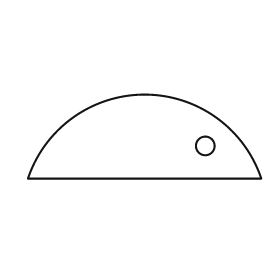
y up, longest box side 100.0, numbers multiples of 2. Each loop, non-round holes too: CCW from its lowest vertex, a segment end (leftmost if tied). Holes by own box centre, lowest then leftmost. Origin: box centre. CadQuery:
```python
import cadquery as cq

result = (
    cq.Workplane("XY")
    .moveTo(-50.0, -18.0)
    .lineTo(50.0, -18.0)
    .threePointArc((0.0, 18.0), (-50.0, -18.0))
    .close()
    .moveTo(26.0, -4.0)
    .circle(4.0)
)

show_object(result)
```